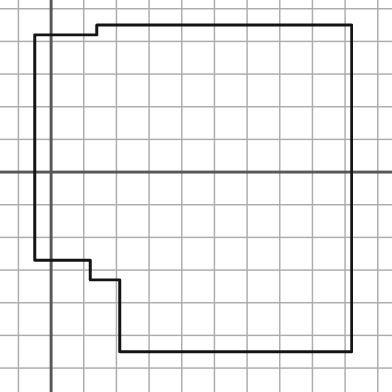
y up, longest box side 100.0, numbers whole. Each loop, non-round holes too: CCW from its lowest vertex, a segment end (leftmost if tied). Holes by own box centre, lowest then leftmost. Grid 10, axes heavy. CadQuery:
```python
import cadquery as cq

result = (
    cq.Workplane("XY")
    .moveTo(21.0, -55.0)
    .lineTo(92.0, -55.0)
    .lineTo(92.0, 45.0)
    .lineTo(14.0, 45.0)
    .lineTo(14.0, 42.0)
    .lineTo(-5.0, 42.0)
    .lineTo(-5.0, -27.0)
    .lineTo(12.0, -27.0)
    .lineTo(12.0, -33.0)
    .lineTo(21.0, -33.0)
    .close()
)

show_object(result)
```